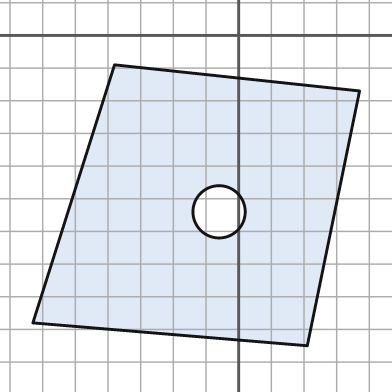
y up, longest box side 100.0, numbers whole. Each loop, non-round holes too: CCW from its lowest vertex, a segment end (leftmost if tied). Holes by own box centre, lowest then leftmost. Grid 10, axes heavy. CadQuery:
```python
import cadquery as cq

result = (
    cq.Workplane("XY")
    .moveTo(21.0, -95.0)
    .lineTo(37.0, -17.0)
    .lineTo(-38.0, -9.0)
    .lineTo(-63.0, -88.0)
    .close()
    .moveTo(-6.0, -54.0)
    .circle(8.0)
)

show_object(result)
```